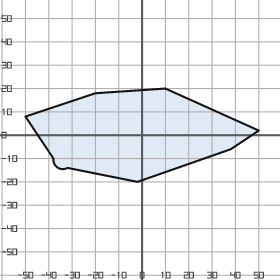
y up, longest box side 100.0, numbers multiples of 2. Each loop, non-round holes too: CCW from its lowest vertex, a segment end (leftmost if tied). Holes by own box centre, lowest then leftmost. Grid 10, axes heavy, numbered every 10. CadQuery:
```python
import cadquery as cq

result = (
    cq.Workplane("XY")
    .moveTo(-2.0, -20.0)
    .lineTo(38.0, -6.0)
    .lineTo(50.0, 2.0)
    .lineTo(10.0, 20.0)
    .lineTo(-20.0, 18.0)
    .lineTo(-50.0, 8.0)
    .lineTo(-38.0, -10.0)
    .threePointArc((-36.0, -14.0), (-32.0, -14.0))
    .close()
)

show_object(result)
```